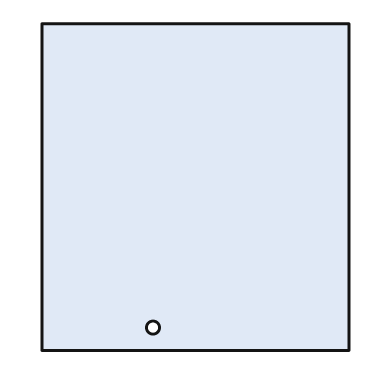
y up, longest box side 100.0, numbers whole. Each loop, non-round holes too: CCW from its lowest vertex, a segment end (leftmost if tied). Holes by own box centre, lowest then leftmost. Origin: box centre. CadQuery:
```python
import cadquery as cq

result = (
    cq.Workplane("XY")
    .moveTo(-47.0, -50.0)
    .lineTo(47.0, -50.0)
    .lineTo(47.0, 50.0)
    .lineTo(-47.0, 50.0)
    .close()
    .moveTo(-13.0, -43.0)
    .circle(2.0)
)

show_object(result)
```